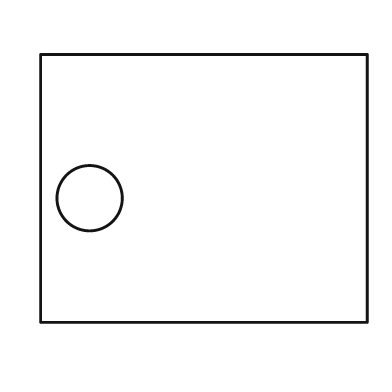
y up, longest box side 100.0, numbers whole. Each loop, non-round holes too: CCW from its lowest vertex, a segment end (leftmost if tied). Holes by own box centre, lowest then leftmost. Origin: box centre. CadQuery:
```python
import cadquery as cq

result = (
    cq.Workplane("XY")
    .moveTo(-50.0, -41.0)
    .lineTo(50.0, -41.0)
    .lineTo(50.0, 41.0)
    .lineTo(-50.0, 41.0)
    .close()
    .moveTo(-35.0, -3.0)
    .circle(10.0)
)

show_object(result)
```